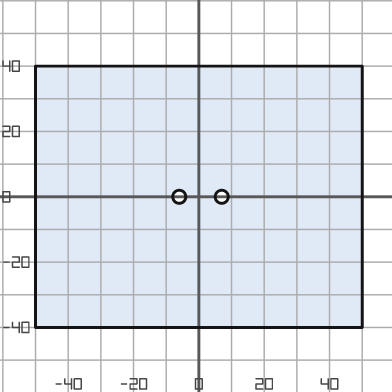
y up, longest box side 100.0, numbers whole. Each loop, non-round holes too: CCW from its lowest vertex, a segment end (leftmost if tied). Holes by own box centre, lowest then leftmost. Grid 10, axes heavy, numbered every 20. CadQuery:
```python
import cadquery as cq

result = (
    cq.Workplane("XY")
    .moveTo(-50.0, -40.0)
    .lineTo(50.0, -40.0)
    .lineTo(50.0, 40.0)
    .lineTo(-50.0, 40.0)
    .close()
    .moveTo(-6.0, 0.0)
    .circle(2.0)
    .moveTo(7.0, 0.0)
    .circle(2.0)
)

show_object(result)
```